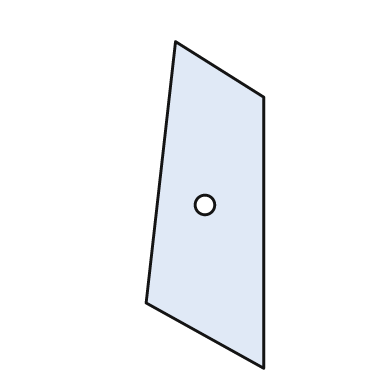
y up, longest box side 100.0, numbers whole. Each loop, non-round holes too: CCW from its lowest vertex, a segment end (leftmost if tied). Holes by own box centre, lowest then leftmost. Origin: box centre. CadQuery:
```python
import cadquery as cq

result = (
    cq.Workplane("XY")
    .moveTo(18.0, -50.0)
    .lineTo(18.0, 33.0)
    .lineTo(-9.0, 50.0)
    .lineTo(-18.0, -30.0)
    .close()
    .moveTo(0.0, 0.0)
    .circle(3.0)
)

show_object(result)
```